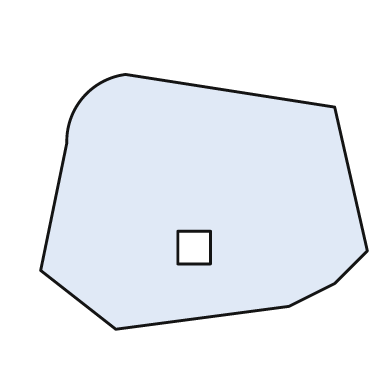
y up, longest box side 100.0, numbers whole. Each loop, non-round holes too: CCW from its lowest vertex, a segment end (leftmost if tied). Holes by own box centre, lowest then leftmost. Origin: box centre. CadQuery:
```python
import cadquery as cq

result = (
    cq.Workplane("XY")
    .moveTo(-27.0, -39.0)
    .lineTo(26.0, -32.0)
    .lineTo(40.0, -25.0)
    .lineTo(50.0, -15.0)
    .lineTo(40.0, 29.0)
    .lineTo(-24.0, 39.0)
    .threePointArc((-37.0, 32.0), (-42.0, 18.0))
    .lineTo(-50.0, -21.0)
    .close()
    .moveTo(-8.0, -19.0)
    .lineTo(2.0, -19.0)
    .lineTo(2.0, -9.0)
    .lineTo(-8.0, -9.0)
    .close()
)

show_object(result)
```